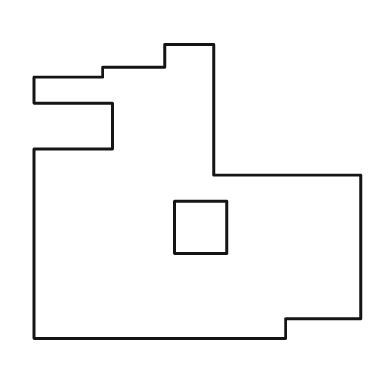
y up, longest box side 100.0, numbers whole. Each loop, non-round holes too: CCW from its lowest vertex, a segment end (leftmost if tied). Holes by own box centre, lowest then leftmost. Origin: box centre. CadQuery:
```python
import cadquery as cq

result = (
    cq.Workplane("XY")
    .moveTo(-50.0, -45.0)
    .lineTo(27.0, -45.0)
    .lineTo(27.0, -39.0)
    .lineTo(50.0, -39.0)
    .lineTo(50.0, 5.0)
    .lineTo(5.0, 5.0)
    .lineTo(5.0, 45.0)
    .lineTo(-10.0, 45.0)
    .lineTo(-10.0, 38.0)
    .lineTo(-29.0, 38.0)
    .lineTo(-29.0, 35.0)
    .lineTo(-50.0, 35.0)
    .lineTo(-50.0, 27.0)
    .lineTo(-26.0, 27.0)
    .lineTo(-26.0, 13.0)
    .lineTo(-50.0, 13.0)
    .close()
    .moveTo(-7.0, -19.0)
    .lineTo(9.0, -19.0)
    .lineTo(9.0, -3.0)
    .lineTo(-7.0, -3.0)
    .close()
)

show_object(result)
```